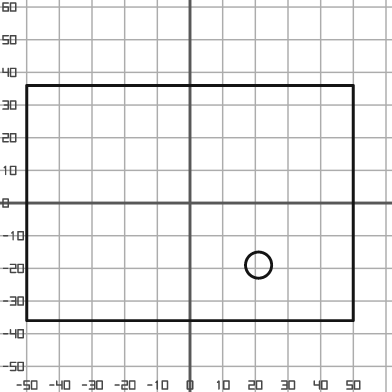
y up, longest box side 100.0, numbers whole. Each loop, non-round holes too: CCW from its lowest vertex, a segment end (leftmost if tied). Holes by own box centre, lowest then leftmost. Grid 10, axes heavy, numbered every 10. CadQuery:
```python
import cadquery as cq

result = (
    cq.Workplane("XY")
    .moveTo(-50.0, -36.0)
    .lineTo(50.0, -36.0)
    .lineTo(50.0, 36.0)
    .lineTo(-50.0, 36.0)
    .close()
    .moveTo(21.0, -19.0)
    .circle(4.0)
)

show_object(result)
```